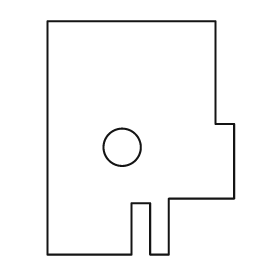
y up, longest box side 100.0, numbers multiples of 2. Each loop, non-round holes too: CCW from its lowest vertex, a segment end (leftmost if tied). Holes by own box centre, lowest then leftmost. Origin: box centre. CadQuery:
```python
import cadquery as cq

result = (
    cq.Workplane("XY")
    .moveTo(-40.0, -50.0)
    .lineTo(-4.0, -50.0)
    .lineTo(-4.0, -28.0)
    .lineTo(4.0, -28.0)
    .lineTo(4.0, -50.0)
    .lineTo(12.0, -50.0)
    .lineTo(12.0, -26.0)
    .lineTo(40.0, -26.0)
    .lineTo(40.0, 6.0)
    .lineTo(32.0, 6.0)
    .lineTo(32.0, 50.0)
    .lineTo(-40.0, 50.0)
    .close()
    .moveTo(-8.0, -4.0)
    .circle(8.0)
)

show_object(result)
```